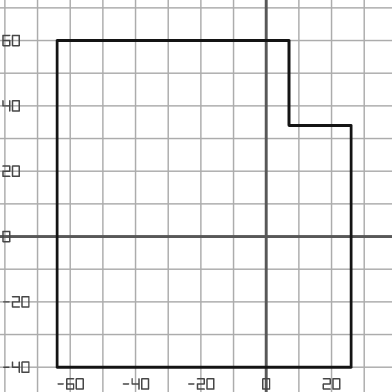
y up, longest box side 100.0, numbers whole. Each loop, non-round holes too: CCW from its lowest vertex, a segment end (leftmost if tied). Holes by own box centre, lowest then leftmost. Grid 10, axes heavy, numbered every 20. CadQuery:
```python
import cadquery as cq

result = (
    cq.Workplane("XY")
    .moveTo(-64.0, -40.0)
    .lineTo(26.0, -40.0)
    .lineTo(26.0, 34.0)
    .lineTo(7.0, 34.0)
    .lineTo(7.0, 60.0)
    .lineTo(-64.0, 60.0)
    .close()
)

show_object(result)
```